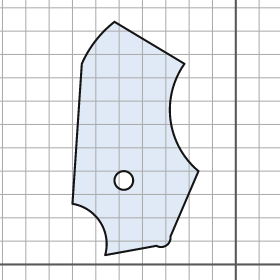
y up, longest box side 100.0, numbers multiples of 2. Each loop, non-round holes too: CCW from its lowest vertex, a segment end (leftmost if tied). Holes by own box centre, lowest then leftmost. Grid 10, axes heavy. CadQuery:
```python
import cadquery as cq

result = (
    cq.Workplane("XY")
    .moveTo(-56.0, 4.0)
    .lineTo(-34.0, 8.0)
    .threePointArc((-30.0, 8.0), (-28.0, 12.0))
    .lineTo(-16.0, 40.0)
    .threePointArc((-28.0, 62.0), (-22.0, 86.0))
    .lineTo(-52.0, 104.0)
    .threePointArc((-60.0, 96.0), (-66.0, 86.0))
    .lineTo(-70.0, 26.0)
    .threePointArc((-58.0, 18.0), (-56.0, 4.0))
    .close()
    .moveTo(-48.0, 36.0)
    .circle(4.0)
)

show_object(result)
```